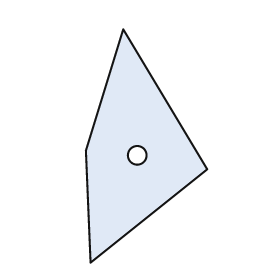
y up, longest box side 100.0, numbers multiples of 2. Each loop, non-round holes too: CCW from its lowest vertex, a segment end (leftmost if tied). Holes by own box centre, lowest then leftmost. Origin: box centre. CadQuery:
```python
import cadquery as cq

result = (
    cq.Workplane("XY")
    .moveTo(-24.0, -50.0)
    .lineTo(26.0, -10.0)
    .lineTo(-10.0, 50.0)
    .lineTo(-26.0, -2.0)
    .close()
    .moveTo(-4.0, -4.0)
    .circle(4.0)
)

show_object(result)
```